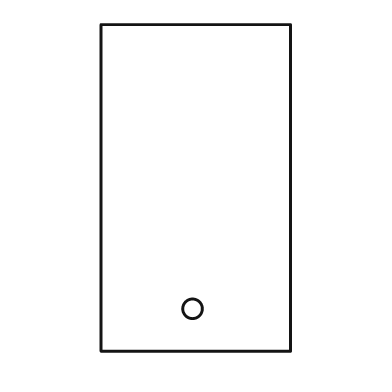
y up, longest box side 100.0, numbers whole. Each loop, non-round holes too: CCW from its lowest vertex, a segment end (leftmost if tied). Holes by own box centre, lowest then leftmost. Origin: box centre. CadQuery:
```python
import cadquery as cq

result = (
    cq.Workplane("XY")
    .moveTo(-29.0, -50.0)
    .lineTo(29.0, -50.0)
    .lineTo(29.0, 50.0)
    .lineTo(-29.0, 50.0)
    .close()
    .moveTo(-1.0, -37.0)
    .circle(3.0)
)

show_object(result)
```